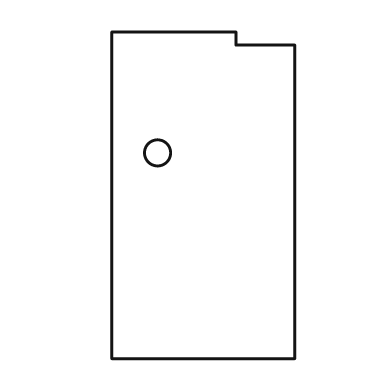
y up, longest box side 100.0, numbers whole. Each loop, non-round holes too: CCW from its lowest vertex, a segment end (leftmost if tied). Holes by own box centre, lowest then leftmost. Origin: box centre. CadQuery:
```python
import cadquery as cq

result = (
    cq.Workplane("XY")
    .moveTo(-28.0, -50.0)
    .lineTo(28.0, -50.0)
    .lineTo(28.0, 46.0)
    .lineTo(10.0, 46.0)
    .lineTo(10.0, 50.0)
    .lineTo(-28.0, 50.0)
    .close()
    .moveTo(-14.0, 13.0)
    .circle(4.0)
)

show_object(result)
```